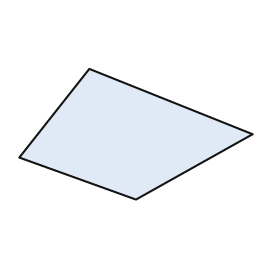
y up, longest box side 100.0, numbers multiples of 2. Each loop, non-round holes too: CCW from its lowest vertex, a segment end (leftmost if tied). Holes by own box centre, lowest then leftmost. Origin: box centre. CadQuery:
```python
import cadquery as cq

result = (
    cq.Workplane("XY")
    .moveTo(0.0, -28.0)
    .lineTo(50.0, 0.0)
    .lineTo(-20.0, 28.0)
    .lineTo(-50.0, -10.0)
    .close()
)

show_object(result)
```